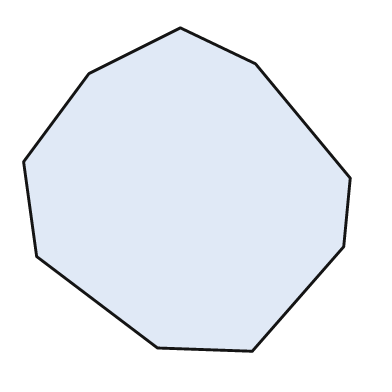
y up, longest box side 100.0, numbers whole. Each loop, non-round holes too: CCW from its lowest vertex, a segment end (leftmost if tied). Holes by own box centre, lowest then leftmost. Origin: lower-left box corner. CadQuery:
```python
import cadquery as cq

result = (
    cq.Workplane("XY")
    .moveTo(70.0, 0.0)
    .lineTo(98.0, 32.0)
    .lineTo(100.0, 53.0)
    .lineTo(71.0, 88.0)
    .lineTo(48.0, 99.0)
    .lineTo(20.0, 85.0)
    .lineTo(0.0, 58.0)
    .lineTo(4.0, 29.0)
    .lineTo(41.0, 1.0)
    .close()
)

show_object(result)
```